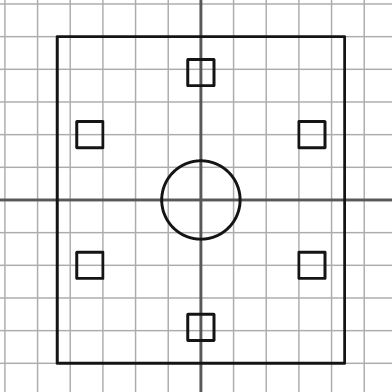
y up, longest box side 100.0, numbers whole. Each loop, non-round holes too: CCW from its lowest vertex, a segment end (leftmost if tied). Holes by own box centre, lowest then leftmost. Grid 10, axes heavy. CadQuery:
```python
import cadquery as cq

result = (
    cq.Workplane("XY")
    .moveTo(-44.0, -50.0)
    .lineTo(44.0, -50.0)
    .lineTo(44.0, 50.0)
    .lineTo(-44.0, 50.0)
    .close()
    .moveTo(-4.0, -43.0)
    .lineTo(4.0, -43.0)
    .lineTo(4.0, -35.0)
    .lineTo(-4.0, -35.0)
    .close()
    .moveTo(-38.0, -24.0)
    .lineTo(-30.0, -24.0)
    .lineTo(-30.0, -16.0)
    .lineTo(-38.0, -16.0)
    .close()
    .moveTo(30.0, -24.0)
    .lineTo(38.0, -24.0)
    .lineTo(38.0, -16.0)
    .lineTo(30.0, -16.0)
    .close()
    .moveTo(0.0, 0.0)
    .circle(12.0)
    .moveTo(-38.0, 16.0)
    .lineTo(-30.0, 16.0)
    .lineTo(-30.0, 24.0)
    .lineTo(-38.0, 24.0)
    .close()
    .moveTo(30.0, 16.0)
    .lineTo(38.0, 16.0)
    .lineTo(38.0, 24.0)
    .lineTo(30.0, 24.0)
    .close()
    .moveTo(-4.0, 35.0)
    .lineTo(4.0, 35.0)
    .lineTo(4.0, 43.0)
    .lineTo(-4.0, 43.0)
    .close()
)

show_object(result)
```